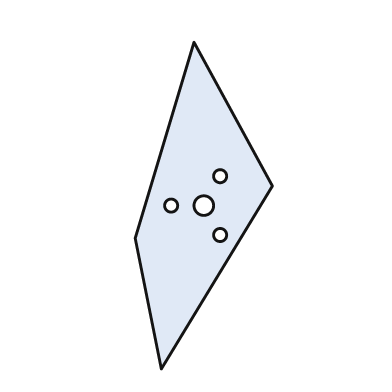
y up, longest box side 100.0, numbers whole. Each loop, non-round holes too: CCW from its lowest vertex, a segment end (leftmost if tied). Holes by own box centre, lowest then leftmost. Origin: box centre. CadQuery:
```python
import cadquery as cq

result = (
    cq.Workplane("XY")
    .moveTo(-13.0, -50.0)
    .lineTo(21.0, 6.0)
    .lineTo(-3.0, 50.0)
    .lineTo(-21.0, -10.0)
    .close()
    .moveTo(5.0, -9.0)
    .circle(2.0)
    .moveTo(-10.0, 0.0)
    .circle(2.0)
    .moveTo(0.0, 0.0)
    .circle(3.0)
    .moveTo(5.0, 9.0)
    .circle(2.0)
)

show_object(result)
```